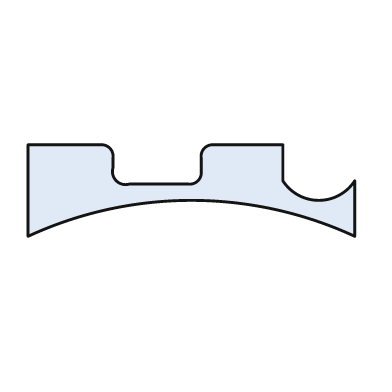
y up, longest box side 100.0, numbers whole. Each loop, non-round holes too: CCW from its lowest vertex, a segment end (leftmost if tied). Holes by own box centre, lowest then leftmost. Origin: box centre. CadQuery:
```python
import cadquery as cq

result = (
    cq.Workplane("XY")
    .moveTo(-50.0, -14.0)
    .threePointArc((0.0, -3.0), (50.0, -14.0))
    .lineTo(50.0, 3.0)
    .threePointArc((39.0, -3.0), (28.0, 3.0))
    .lineTo(28.0, 14.0)
    .lineTo(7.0, 14.0)
    .threePointArc((4.0, 13.0), (3.0, 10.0))
    .lineTo(3.0, 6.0)
    .threePointArc((2.0, 3.0), (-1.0, 2.0))
    .lineTo(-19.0, 2.0)
    .threePointArc((-23.0, 3.0), (-24.0, 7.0))
    .lineTo(-24.0, 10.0)
    .threePointArc((-25.0, 13.0), (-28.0, 14.0))
    .lineTo(-50.0, 14.0)
    .close()
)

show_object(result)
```